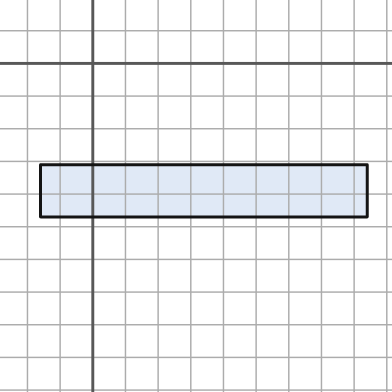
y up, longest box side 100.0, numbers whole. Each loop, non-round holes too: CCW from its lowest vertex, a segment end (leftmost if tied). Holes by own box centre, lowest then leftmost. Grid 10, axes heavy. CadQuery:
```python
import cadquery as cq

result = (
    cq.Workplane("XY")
    .moveTo(-16.0, -47.0)
    .lineTo(84.0, -47.0)
    .lineTo(84.0, -31.0)
    .lineTo(-16.0, -31.0)
    .close()
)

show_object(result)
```